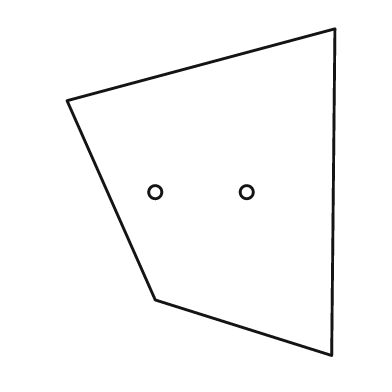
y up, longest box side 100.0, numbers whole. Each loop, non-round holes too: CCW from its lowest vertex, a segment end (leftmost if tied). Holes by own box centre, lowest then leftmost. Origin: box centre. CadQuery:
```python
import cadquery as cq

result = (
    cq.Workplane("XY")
    .moveTo(40.0, -50.0)
    .lineTo(41.0, 50.0)
    .lineTo(-41.0, 28.0)
    .lineTo(-14.0, -33.0)
    .close()
    .moveTo(-14.0, 0.0)
    .circle(2.0)
    .moveTo(14.0, 0.0)
    .circle(2.0)
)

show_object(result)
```